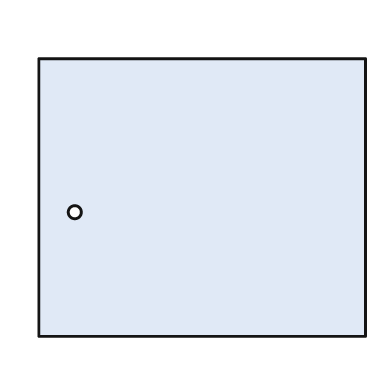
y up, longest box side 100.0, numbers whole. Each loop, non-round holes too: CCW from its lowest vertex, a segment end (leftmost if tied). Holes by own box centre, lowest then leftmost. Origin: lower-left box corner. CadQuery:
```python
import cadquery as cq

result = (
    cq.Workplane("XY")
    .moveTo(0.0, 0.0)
    .lineTo(100.0, 0.0)
    .lineTo(100.0, 85.0)
    .lineTo(0.0, 85.0)
    .close()
    .moveTo(11.0, 38.0)
    .circle(2.0)
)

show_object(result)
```